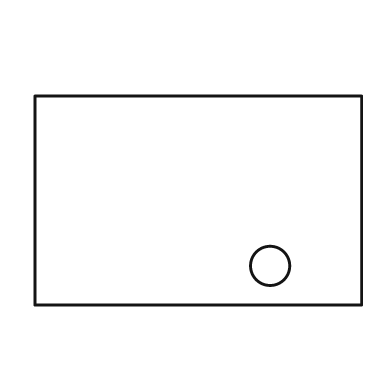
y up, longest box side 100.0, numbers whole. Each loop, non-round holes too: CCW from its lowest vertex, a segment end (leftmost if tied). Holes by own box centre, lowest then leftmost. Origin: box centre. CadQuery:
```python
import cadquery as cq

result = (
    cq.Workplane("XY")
    .moveTo(-50.0, -32.0)
    .lineTo(50.0, -32.0)
    .lineTo(50.0, 32.0)
    .lineTo(-50.0, 32.0)
    .close()
    .moveTo(22.0, -20.0)
    .circle(6.0)
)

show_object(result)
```